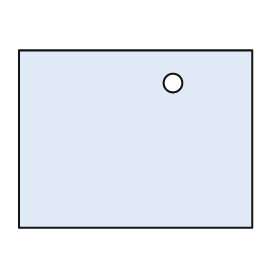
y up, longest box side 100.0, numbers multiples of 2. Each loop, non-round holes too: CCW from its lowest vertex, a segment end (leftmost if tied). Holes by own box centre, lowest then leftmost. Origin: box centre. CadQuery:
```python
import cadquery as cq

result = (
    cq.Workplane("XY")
    .moveTo(-50.0, -38.0)
    .lineTo(50.0, -38.0)
    .lineTo(50.0, 38.0)
    .lineTo(-50.0, 38.0)
    .close()
    .moveTo(16.0, 24.0)
    .circle(4.0)
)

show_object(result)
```